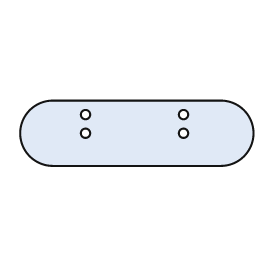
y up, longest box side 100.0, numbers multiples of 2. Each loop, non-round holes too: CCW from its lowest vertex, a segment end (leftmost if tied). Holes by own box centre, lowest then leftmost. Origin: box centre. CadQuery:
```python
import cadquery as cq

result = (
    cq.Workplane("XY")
    .moveTo(-36.0, -14.0)
    .lineTo(36.0, -14.0)
    .threePointArc((50.0, 0.0), (36.0, 14.0))
    .lineTo(-36.0, 14.0)
    .threePointArc((-50.0, 0.0), (-36.0, -14.0))
    .close()
    .moveTo(-22.0, 0.0)
    .circle(2.0)
    .moveTo(20.0, 0.0)
    .circle(2.0)
    .moveTo(-22.0, 8.0)
    .circle(2.0)
    .moveTo(20.0, 8.0)
    .circle(2.0)
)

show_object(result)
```